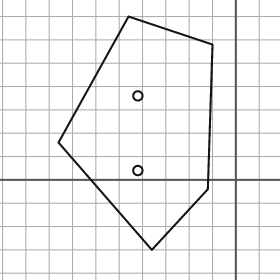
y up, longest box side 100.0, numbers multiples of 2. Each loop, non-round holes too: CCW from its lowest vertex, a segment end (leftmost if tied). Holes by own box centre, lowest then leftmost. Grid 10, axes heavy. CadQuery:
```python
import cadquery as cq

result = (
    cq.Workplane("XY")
    .moveTo(-36.0, -30.0)
    .lineTo(-12.0, -4.0)
    .lineTo(-10.0, 58.0)
    .lineTo(-46.0, 70.0)
    .lineTo(-76.0, 16.0)
    .close()
    .moveTo(-42.0, 4.0)
    .circle(2.0)
    .moveTo(-42.0, 36.0)
    .circle(2.0)
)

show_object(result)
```